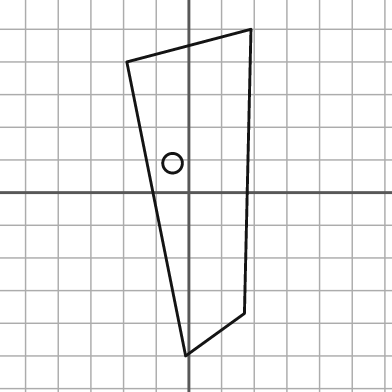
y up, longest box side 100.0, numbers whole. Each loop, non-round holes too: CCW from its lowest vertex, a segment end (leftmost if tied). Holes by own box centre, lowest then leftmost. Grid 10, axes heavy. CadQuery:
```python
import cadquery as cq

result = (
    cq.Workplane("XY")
    .moveTo(-1.0, -50.0)
    .lineTo(17.0, -37.0)
    .lineTo(19.0, 50.0)
    .lineTo(-19.0, 40.0)
    .close()
    .moveTo(-5.0, 9.0)
    .circle(3.0)
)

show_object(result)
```